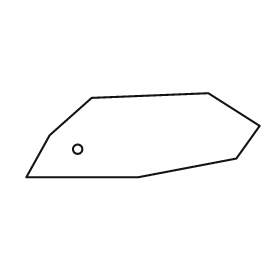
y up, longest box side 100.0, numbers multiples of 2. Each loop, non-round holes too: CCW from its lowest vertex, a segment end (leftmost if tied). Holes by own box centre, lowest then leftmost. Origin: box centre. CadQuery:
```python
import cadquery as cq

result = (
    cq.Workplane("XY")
    .moveTo(-50.0, -18.0)
    .lineTo(-2.0, -18.0)
    .lineTo(40.0, -10.0)
    .lineTo(50.0, 4.0)
    .lineTo(28.0, 18.0)
    .lineTo(-22.0, 16.0)
    .lineTo(-40.0, 0.0)
    .close()
    .moveTo(-28.0, -6.0)
    .circle(2.0)
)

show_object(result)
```